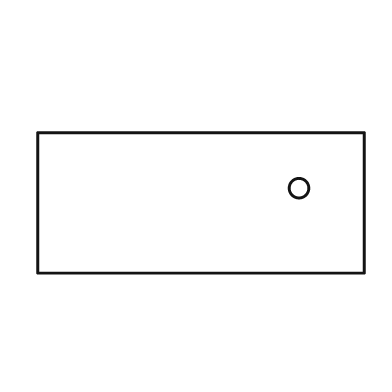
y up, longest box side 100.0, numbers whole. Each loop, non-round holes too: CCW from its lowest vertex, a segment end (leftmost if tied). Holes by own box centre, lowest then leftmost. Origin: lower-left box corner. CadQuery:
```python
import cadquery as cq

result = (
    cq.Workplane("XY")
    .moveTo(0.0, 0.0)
    .lineTo(100.0, 0.0)
    .lineTo(100.0, 43.0)
    .lineTo(0.0, 43.0)
    .close()
    .moveTo(80.0, 26.0)
    .circle(3.0)
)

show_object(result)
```